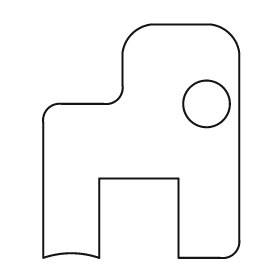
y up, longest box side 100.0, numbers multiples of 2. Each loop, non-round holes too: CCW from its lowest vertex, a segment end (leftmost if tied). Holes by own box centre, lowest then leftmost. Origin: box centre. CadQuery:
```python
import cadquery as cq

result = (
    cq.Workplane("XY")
    .moveTo(-42.0, -50.0)
    .threePointArc((-30.0, -48.0), (-18.0, -50.0))
    .lineTo(-18.0, -16.0)
    .lineTo(16.0, -16.0)
    .lineTo(16.0, -50.0)
    .lineTo(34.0, -50.0)
    .threePointArc((40.0, -48.0), (42.0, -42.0))
    .lineTo(42.0, 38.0)
    .threePointArc((38.0, 46.0), (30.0, 50.0))
    .lineTo(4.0, 50.0)
    .threePointArc((-4.0, 46.0), (-8.0, 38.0))
    .lineTo(-8.0, 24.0)
    .threePointArc((-10.0, 18.0), (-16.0, 16.0))
    .lineTo(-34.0, 16.0)
    .threePointArc((-40.0, 14.0), (-42.0, 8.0))
    .close()
    .moveTo(28.0, 16.0)
    .circle(10.0)
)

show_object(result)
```